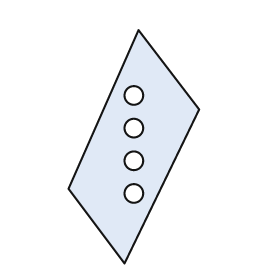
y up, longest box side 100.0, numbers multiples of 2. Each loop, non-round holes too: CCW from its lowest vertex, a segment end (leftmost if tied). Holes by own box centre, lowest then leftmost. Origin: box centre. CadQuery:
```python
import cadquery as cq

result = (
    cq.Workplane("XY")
    .moveTo(-4.0, -50.0)
    .lineTo(28.0, 16.0)
    .lineTo(2.0, 50.0)
    .lineTo(-28.0, -18.0)
    .close()
    .moveTo(0.0, -20.0)
    .circle(4.0)
    .moveTo(0.0, -6.0)
    .circle(4.0)
    .moveTo(0.0, 8.0)
    .circle(4.0)
    .moveTo(0.0, 22.0)
    .circle(4.0)
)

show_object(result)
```